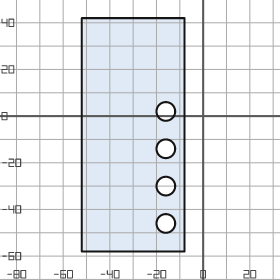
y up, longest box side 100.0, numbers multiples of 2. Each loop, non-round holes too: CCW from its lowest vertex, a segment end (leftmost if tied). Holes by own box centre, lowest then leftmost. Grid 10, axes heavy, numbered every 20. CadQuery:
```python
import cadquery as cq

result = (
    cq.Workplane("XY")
    .moveTo(-52.0, -58.0)
    .lineTo(-8.0, -58.0)
    .lineTo(-8.0, 42.0)
    .lineTo(-52.0, 42.0)
    .close()
    .moveTo(-16.0, -46.0)
    .circle(4.0)
    .moveTo(-16.0, -30.0)
    .circle(4.0)
    .moveTo(-16.0, -14.0)
    .circle(4.0)
    .moveTo(-16.0, 2.0)
    .circle(4.0)
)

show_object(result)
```